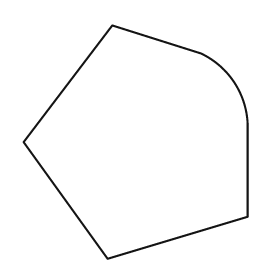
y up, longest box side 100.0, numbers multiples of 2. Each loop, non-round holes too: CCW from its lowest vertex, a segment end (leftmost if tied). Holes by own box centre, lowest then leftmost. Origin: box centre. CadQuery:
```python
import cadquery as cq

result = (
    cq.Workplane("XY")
    .moveTo(-12.0, -50.0)
    .lineTo(48.0, -32.0)
    .lineTo(48.0, 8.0)
    .threePointArc((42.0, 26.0), (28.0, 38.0))
    .lineTo(-10.0, 50.0)
    .lineTo(-48.0, 0.0)
    .close()
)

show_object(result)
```